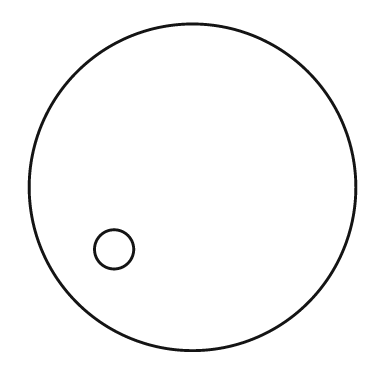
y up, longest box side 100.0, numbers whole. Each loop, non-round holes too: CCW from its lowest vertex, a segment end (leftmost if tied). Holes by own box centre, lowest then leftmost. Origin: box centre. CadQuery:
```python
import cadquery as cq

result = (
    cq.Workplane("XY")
    .moveTo(0.0, 0.0)
    .circle(50.0)
    .moveTo(-24.0, -19.0)
    .circle(6.0)
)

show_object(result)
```